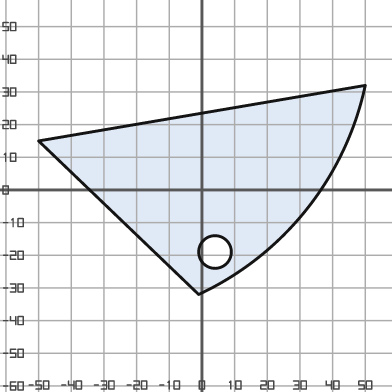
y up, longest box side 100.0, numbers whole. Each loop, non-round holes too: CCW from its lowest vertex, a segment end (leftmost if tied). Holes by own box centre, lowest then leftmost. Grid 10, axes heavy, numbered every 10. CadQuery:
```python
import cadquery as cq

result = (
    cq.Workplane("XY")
    .moveTo(-1.0, -32.0)
    .threePointArc((32.0, -6.0), (50.0, 32.0))
    .lineTo(-50.0, 15.0)
    .close()
    .moveTo(4.0, -19.0)
    .circle(5.0)
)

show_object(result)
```